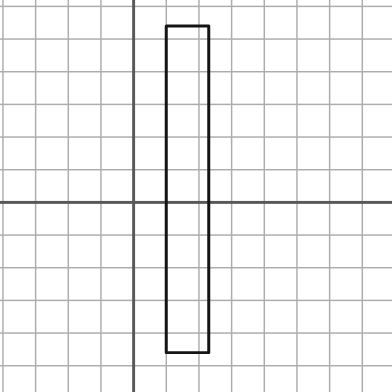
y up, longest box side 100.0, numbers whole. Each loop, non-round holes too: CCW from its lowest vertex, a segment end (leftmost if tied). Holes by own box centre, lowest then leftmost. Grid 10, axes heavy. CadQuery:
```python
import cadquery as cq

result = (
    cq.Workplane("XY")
    .moveTo(10.0, -46.0)
    .lineTo(23.0, -46.0)
    .lineTo(23.0, 54.0)
    .lineTo(10.0, 54.0)
    .close()
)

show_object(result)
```